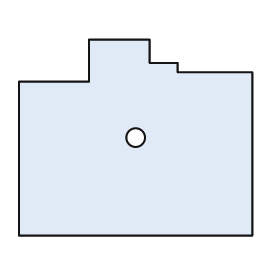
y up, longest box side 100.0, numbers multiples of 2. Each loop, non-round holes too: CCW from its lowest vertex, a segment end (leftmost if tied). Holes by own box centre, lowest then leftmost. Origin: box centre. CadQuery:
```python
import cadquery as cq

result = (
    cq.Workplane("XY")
    .moveTo(-50.0, -42.0)
    .lineTo(50.0, -42.0)
    .lineTo(50.0, 28.0)
    .lineTo(18.0, 28.0)
    .lineTo(18.0, 32.0)
    .lineTo(6.0, 32.0)
    .lineTo(6.0, 42.0)
    .lineTo(-20.0, 42.0)
    .lineTo(-20.0, 24.0)
    .lineTo(-50.0, 24.0)
    .close()
    .moveTo(0.0, 0.0)
    .circle(4.0)
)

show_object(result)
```